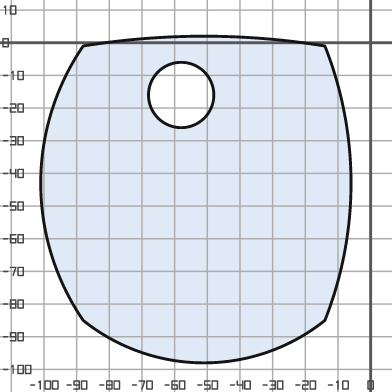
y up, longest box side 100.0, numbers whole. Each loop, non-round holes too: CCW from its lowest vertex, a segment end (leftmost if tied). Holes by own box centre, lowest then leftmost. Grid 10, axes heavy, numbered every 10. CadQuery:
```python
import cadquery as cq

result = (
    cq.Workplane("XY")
    .moveTo(-88.0, -85.0)
    .threePointArc((-51.0, -98.0), (-14.0, -85.0))
    .threePointArc((-6.0, -43.0), (-14.0, -1.0))
    .threePointArc((-51.0, 2.0), (-88.0, -1.0))
    .threePointArc((-101.0, -43.0), (-88.0, -85.0))
    .close()
    .moveTo(-58.0, -16.0)
    .circle(10.0)
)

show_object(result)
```